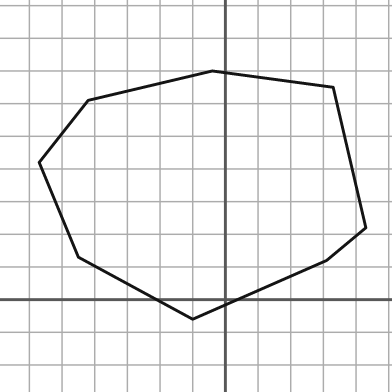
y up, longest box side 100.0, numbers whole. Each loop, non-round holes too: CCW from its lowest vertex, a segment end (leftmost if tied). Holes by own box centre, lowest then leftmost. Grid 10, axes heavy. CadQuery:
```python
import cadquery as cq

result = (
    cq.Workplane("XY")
    .moveTo(-10.0, -6.0)
    .lineTo(31.0, 12.0)
    .lineTo(43.0, 22.0)
    .lineTo(33.0, 65.0)
    .lineTo(-4.0, 70.0)
    .lineTo(-42.0, 61.0)
    .lineTo(-57.0, 42.0)
    .lineTo(-45.0, 13.0)
    .close()
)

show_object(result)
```